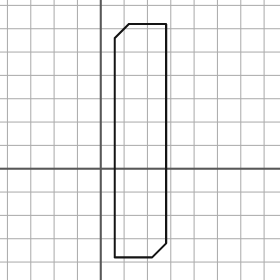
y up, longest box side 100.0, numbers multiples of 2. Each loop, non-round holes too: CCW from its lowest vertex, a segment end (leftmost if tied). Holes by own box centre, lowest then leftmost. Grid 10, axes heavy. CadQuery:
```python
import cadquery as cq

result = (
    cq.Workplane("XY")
    .moveTo(6.0, -38.0)
    .lineTo(22.0, -38.0)
    .lineTo(28.0, -32.0)
    .lineTo(28.0, 62.0)
    .lineTo(12.0, 62.0)
    .lineTo(6.0, 56.0)
    .close()
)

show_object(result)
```